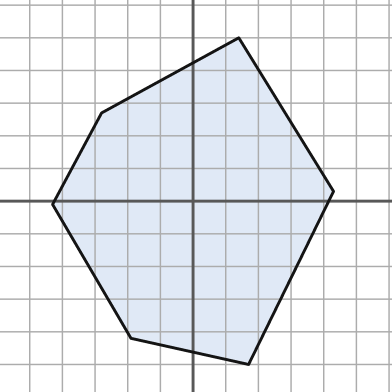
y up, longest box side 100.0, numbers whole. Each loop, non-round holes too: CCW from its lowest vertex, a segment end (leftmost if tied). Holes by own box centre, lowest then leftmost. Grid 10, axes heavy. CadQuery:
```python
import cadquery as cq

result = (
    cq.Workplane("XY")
    .moveTo(17.0, -50.0)
    .lineTo(43.0, 3.0)
    .lineTo(14.0, 50.0)
    .lineTo(-28.0, 27.0)
    .lineTo(-43.0, -1.0)
    .lineTo(-19.0, -42.0)
    .close()
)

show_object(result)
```